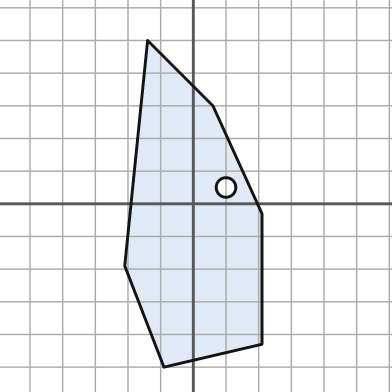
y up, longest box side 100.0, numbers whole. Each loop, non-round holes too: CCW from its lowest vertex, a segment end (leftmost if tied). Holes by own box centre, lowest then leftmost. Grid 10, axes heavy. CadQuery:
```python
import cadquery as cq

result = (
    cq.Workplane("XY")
    .moveTo(-9.0, -50.0)
    .lineTo(21.0, -43.0)
    .lineTo(21.0, -3.0)
    .lineTo(6.0, 30.0)
    .lineTo(-14.0, 50.0)
    .lineTo(-21.0, -19.0)
    .close()
    .moveTo(10.0, 5.0)
    .circle(3.0)
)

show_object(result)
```